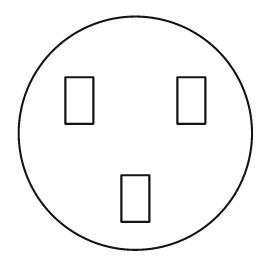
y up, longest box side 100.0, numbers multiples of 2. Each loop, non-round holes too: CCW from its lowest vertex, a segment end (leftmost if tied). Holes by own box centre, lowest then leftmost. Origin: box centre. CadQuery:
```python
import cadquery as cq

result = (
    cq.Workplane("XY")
    .moveTo(0.0, 0.0)
    .circle(50.0)
    .moveTo(-6.0, -38.0)
    .lineTo(6.0, -38.0)
    .lineTo(6.0, -18.0)
    .lineTo(-6.0, -18.0)
    .close()
    .moveTo(-30.0, 4.0)
    .lineTo(-18.0, 4.0)
    .lineTo(-18.0, 24.0)
    .lineTo(-30.0, 24.0)
    .close()
    .moveTo(18.0, 4.0)
    .lineTo(30.0, 4.0)
    .lineTo(30.0, 24.0)
    .lineTo(18.0, 24.0)
    .close()
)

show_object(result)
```